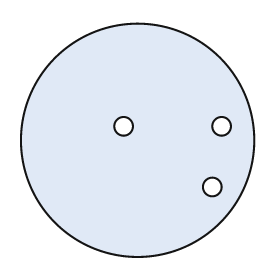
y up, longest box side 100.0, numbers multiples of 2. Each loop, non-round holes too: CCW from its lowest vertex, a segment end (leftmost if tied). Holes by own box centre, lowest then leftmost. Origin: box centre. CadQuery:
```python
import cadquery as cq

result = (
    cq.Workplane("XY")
    .moveTo(0.0, 0.0)
    .circle(50.0)
    .moveTo(32.0, -20.0)
    .circle(4.0)
    .moveTo(-6.0, 6.0)
    .circle(4.0)
    .moveTo(36.0, 6.0)
    .circle(4.0)
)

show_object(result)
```